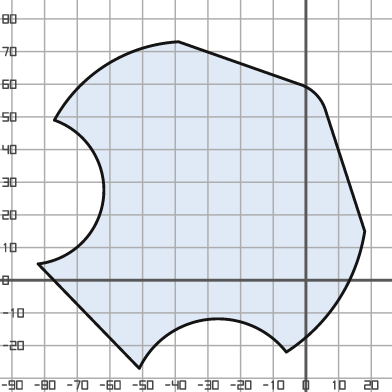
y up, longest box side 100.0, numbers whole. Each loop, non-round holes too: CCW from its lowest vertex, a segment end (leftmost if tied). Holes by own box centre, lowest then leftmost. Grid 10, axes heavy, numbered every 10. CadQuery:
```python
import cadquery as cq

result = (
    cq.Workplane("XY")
    .moveTo(-51.0, -27.0)
    .threePointArc((-30.0, -12.0), (-6.0, -22.0))
    .threePointArc((10.0, -6.0), (18.0, 15.0))
    .lineTo(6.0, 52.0)
    .threePointArc((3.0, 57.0), (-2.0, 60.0))
    .lineTo(-39.0, 73.0)
    .threePointArc((-61.0, 66.0), (-77.0, 49.0))
    .threePointArc((-62.0, 25.0), (-82.0, 5.0))
    .close()
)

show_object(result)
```